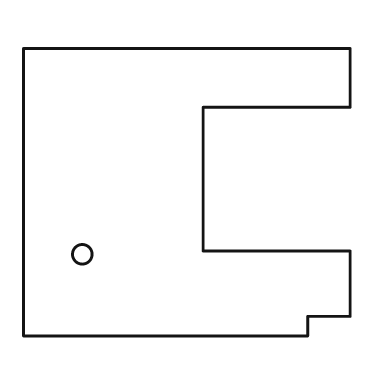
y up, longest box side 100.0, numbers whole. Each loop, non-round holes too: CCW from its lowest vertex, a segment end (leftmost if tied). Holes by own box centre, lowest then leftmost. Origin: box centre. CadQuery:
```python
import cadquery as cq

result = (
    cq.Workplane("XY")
    .moveTo(-50.0, -44.0)
    .lineTo(37.0, -44.0)
    .lineTo(37.0, -38.0)
    .lineTo(50.0, -38.0)
    .lineTo(50.0, -18.0)
    .lineTo(5.0, -18.0)
    .lineTo(5.0, 26.0)
    .lineTo(50.0, 26.0)
    .lineTo(50.0, 44.0)
    .lineTo(-50.0, 44.0)
    .close()
    .moveTo(-32.0, -19.0)
    .circle(3.0)
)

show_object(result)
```